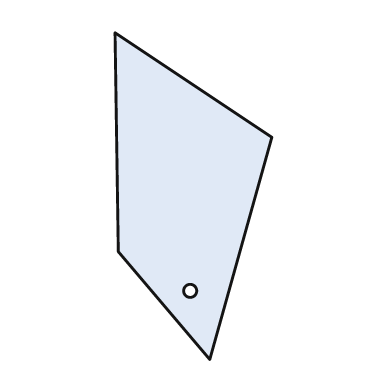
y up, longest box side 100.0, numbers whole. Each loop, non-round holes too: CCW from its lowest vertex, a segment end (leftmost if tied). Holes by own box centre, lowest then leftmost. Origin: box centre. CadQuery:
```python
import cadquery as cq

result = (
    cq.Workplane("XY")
    .moveTo(5.0, -50.0)
    .lineTo(24.0, 18.0)
    .lineTo(-24.0, 50.0)
    .lineTo(-23.0, -17.0)
    .close()
    .moveTo(-1.0, -29.0)
    .circle(2.0)
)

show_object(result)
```